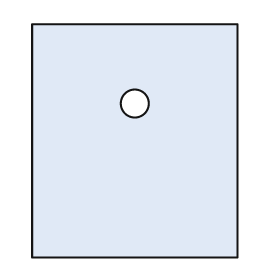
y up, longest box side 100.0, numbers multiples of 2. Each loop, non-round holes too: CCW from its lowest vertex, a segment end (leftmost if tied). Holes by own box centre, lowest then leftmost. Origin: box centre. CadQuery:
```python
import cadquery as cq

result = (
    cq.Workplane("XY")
    .moveTo(-44.0, -50.0)
    .lineTo(44.0, -50.0)
    .lineTo(44.0, 50.0)
    .lineTo(-44.0, 50.0)
    .close()
    .moveTo(0.0, 16.0)
    .circle(6.0)
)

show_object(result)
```